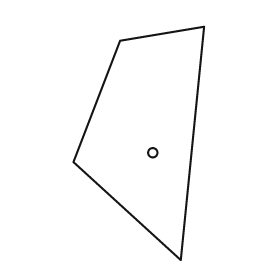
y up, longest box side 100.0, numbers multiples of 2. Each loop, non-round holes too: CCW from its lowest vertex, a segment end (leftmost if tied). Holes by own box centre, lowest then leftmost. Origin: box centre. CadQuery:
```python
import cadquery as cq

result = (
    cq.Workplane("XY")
    .moveTo(18.0, -50.0)
    .lineTo(28.0, 50.0)
    .lineTo(-8.0, 44.0)
    .lineTo(-28.0, -8.0)
    .close()
    .moveTo(6.0, -4.0)
    .circle(2.0)
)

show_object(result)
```